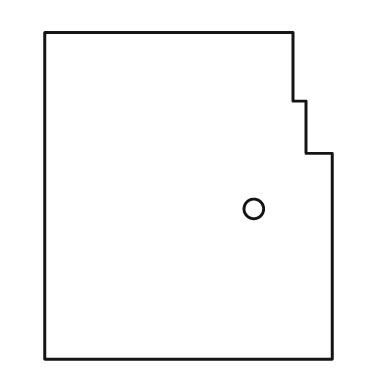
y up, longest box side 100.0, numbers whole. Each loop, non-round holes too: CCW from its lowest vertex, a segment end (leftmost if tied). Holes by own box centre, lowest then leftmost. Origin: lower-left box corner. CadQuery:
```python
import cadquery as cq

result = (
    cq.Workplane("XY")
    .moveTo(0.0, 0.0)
    .lineTo(88.0, 0.0)
    .lineTo(88.0, 63.0)
    .lineTo(80.0, 63.0)
    .lineTo(80.0, 79.0)
    .lineTo(76.0, 79.0)
    .lineTo(76.0, 100.0)
    .lineTo(0.0, 100.0)
    .close()
    .moveTo(64.0, 46.0)
    .circle(3.0)
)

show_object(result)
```